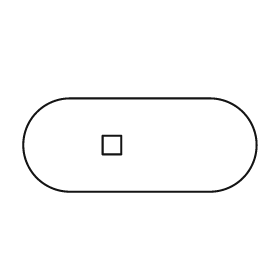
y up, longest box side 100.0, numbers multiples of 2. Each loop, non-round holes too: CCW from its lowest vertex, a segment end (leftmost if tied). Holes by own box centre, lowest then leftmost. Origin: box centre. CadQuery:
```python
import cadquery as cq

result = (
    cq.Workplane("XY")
    .moveTo(-30.0, -20.0)
    .lineTo(30.0, -20.0)
    .threePointArc((50.0, 0.0), (30.0, 20.0))
    .lineTo(-30.0, 20.0)
    .threePointArc((-50.0, 0.0), (-30.0, -20.0))
    .close()
    .moveTo(-16.0, -4.0)
    .lineTo(-8.0, -4.0)
    .lineTo(-8.0, 4.0)
    .lineTo(-16.0, 4.0)
    .close()
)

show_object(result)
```